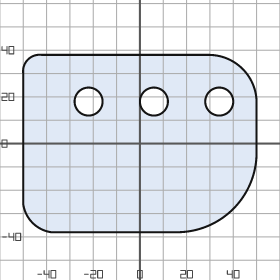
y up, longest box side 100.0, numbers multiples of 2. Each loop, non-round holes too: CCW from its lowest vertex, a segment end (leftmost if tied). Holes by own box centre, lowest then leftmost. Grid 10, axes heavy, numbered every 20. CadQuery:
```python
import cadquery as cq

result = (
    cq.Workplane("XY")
    .moveTo(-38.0, -38.0)
    .lineTo(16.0, -38.0)
    .threePointArc((40.0, -28.0), (50.0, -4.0))
    .lineTo(50.0, 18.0)
    .threePointArc((44.0, 32.0), (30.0, 38.0))
    .lineTo(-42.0, 38.0)
    .threePointArc((-48.0, 36.0), (-50.0, 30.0))
    .lineTo(-50.0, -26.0)
    .threePointArc((-46.0, -34.0), (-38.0, -38.0))
    .close()
    .moveTo(-22.0, 18.0)
    .circle(6.0)
    .moveTo(6.0, 18.0)
    .circle(6.0)
    .moveTo(34.0, 18.0)
    .circle(6.0)
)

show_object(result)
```